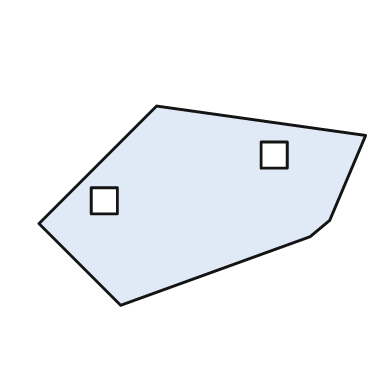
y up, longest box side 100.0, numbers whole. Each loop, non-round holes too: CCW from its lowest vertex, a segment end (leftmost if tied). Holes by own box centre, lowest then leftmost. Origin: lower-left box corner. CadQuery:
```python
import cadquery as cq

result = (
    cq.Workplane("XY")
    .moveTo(25.0, 0.0)
    .lineTo(83.0, 21.0)
    .lineTo(89.0, 26.0)
    .lineTo(100.0, 52.0)
    .lineTo(36.0, 61.0)
    .lineTo(0.0, 25.0)
    .close()
    .moveTo(16.0, 28.0)
    .lineTo(24.0, 28.0)
    .lineTo(24.0, 36.0)
    .lineTo(16.0, 36.0)
    .close()
    .moveTo(68.0, 42.0)
    .lineTo(76.0, 42.0)
    .lineTo(76.0, 50.0)
    .lineTo(68.0, 50.0)
    .close()
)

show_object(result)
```